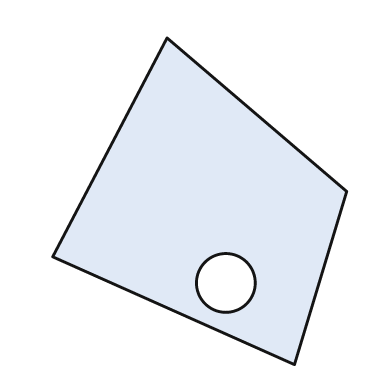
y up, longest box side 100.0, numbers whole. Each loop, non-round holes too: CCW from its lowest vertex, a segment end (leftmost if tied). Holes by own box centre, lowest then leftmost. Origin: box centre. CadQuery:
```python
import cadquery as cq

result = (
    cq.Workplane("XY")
    .moveTo(29.0, -50.0)
    .lineTo(45.0, 3.0)
    .lineTo(-10.0, 50.0)
    .lineTo(-45.0, -17.0)
    .close()
    .moveTo(8.0, -25.0)
    .circle(9.0)
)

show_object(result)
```